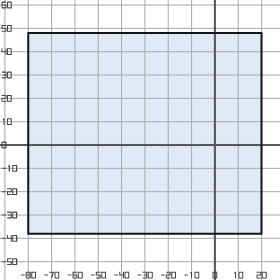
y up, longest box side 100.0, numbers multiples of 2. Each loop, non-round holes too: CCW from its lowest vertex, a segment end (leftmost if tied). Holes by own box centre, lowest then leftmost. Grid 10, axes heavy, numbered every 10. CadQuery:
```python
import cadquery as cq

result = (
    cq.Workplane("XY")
    .moveTo(-80.0, -38.0)
    .lineTo(20.0, -38.0)
    .lineTo(20.0, 48.0)
    .lineTo(-80.0, 48.0)
    .close()
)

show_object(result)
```